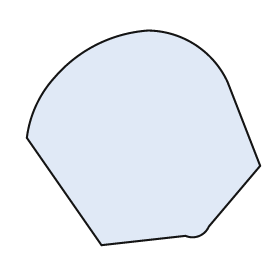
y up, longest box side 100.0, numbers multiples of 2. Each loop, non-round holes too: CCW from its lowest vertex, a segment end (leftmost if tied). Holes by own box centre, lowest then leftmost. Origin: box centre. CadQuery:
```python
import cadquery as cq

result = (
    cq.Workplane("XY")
    .moveTo(-18.0, -46.0)
    .lineTo(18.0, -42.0)
    .threePointArc((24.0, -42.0), (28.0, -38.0))
    .lineTo(50.0, -12.0)
    .lineTo(36.0, 24.0)
    .threePointArc((22.0, 40.0), (2.0, 46.0))
    .threePointArc((-20.0, 40.0), (-38.0, 26.0))
    .threePointArc((-46.0, 14.0), (-50.0, 0.0))
    .close()
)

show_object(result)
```